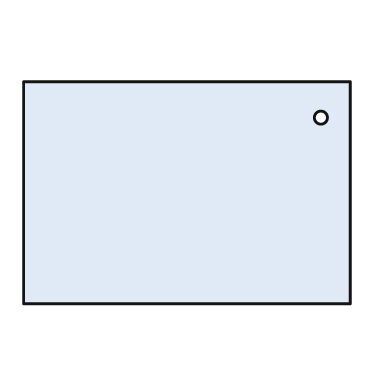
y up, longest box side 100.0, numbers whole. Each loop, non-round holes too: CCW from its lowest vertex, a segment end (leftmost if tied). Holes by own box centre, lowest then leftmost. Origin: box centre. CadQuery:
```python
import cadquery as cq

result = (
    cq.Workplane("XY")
    .moveTo(-50.0, -34.0)
    .lineTo(50.0, -34.0)
    .lineTo(50.0, 34.0)
    .lineTo(-50.0, 34.0)
    .close()
    .moveTo(41.0, 23.0)
    .circle(2.0)
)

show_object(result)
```